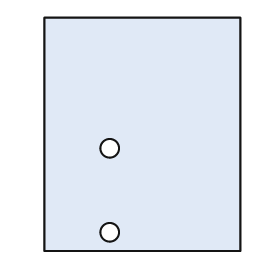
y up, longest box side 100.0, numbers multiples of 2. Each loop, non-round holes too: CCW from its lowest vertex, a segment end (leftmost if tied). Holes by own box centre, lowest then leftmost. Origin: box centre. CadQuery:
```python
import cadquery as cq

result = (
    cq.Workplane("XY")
    .moveTo(-42.0, -50.0)
    .lineTo(42.0, -50.0)
    .lineTo(42.0, 50.0)
    .lineTo(-42.0, 50.0)
    .close()
    .moveTo(-14.0, -42.0)
    .circle(4.0)
    .moveTo(-14.0, -6.0)
    .circle(4.0)
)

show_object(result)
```